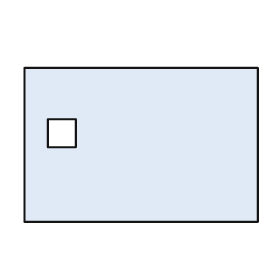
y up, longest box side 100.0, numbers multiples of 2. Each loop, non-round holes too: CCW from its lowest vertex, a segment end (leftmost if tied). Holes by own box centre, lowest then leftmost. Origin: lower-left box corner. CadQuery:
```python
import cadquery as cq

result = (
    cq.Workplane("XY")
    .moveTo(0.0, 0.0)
    .lineTo(100.0, 0.0)
    .lineTo(100.0, 66.0)
    .lineTo(0.0, 66.0)
    .close()
    .moveTo(10.0, 32.0)
    .lineTo(22.0, 32.0)
    .lineTo(22.0, 44.0)
    .lineTo(10.0, 44.0)
    .close()
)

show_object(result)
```